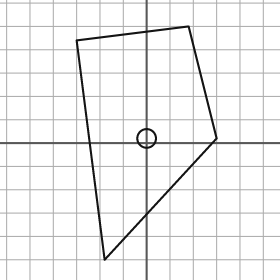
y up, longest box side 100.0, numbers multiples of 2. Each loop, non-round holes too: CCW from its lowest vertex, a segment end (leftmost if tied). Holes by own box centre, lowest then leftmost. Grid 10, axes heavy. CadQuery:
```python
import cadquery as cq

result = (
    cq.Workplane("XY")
    .moveTo(-18.0, -50.0)
    .lineTo(30.0, 2.0)
    .lineTo(18.0, 50.0)
    .lineTo(-30.0, 44.0)
    .close()
    .moveTo(0.0, 2.0)
    .circle(4.0)
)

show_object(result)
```